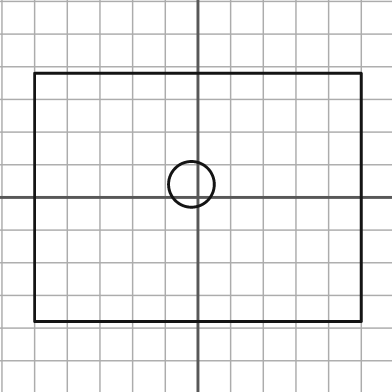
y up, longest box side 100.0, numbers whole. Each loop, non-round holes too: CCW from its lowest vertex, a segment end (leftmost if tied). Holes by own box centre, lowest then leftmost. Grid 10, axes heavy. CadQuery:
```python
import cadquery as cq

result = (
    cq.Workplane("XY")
    .moveTo(-50.0, -38.0)
    .lineTo(50.0, -38.0)
    .lineTo(50.0, 38.0)
    .lineTo(-50.0, 38.0)
    .close()
    .moveTo(-2.0, 4.0)
    .circle(7.0)
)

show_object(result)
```